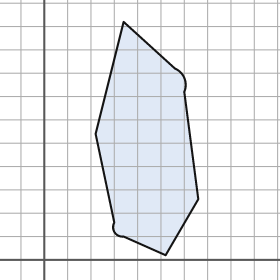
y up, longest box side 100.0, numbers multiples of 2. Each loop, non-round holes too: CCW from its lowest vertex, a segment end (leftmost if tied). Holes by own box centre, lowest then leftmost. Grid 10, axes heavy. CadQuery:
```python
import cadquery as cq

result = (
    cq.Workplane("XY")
    .moveTo(52.0, 2.0)
    .lineTo(66.0, 26.0)
    .lineTo(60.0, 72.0)
    .threePointArc((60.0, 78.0), (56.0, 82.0))
    .lineTo(34.0, 102.0)
    .lineTo(22.0, 54.0)
    .lineTo(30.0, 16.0)
    .threePointArc((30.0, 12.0), (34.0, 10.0))
    .close()
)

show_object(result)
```